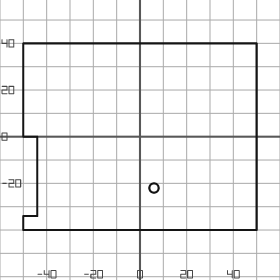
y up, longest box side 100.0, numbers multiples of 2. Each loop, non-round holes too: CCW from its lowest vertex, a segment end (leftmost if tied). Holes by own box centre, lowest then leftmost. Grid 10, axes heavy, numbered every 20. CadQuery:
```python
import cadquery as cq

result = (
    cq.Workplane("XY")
    .moveTo(-50.0, -40.0)
    .lineTo(50.0, -40.0)
    .lineTo(50.0, 40.0)
    .lineTo(-50.0, 40.0)
    .lineTo(-50.0, 0.0)
    .lineTo(-44.0, 0.0)
    .lineTo(-44.0, -34.0)
    .lineTo(-50.0, -34.0)
    .close()
    .moveTo(6.0, -22.0)
    .circle(2.0)
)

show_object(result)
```